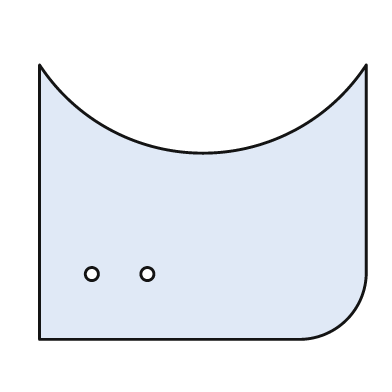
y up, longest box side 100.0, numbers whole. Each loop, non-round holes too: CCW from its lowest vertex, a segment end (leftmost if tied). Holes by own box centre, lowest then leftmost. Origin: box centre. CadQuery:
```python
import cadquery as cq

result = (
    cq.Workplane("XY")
    .moveTo(-50.0, -42.0)
    .lineTo(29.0, -42.0)
    .threePointArc((44.0, -36.0), (50.0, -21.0))
    .lineTo(50.0, 42.0)
    .threePointArc((0.0, 15.0), (-50.0, 42.0))
    .close()
    .moveTo(-34.0, -22.0)
    .circle(2.0)
    .moveTo(-17.0, -22.0)
    .circle(2.0)
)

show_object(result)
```